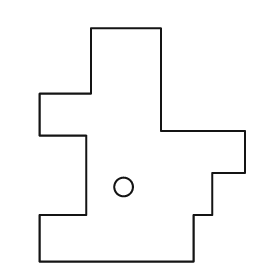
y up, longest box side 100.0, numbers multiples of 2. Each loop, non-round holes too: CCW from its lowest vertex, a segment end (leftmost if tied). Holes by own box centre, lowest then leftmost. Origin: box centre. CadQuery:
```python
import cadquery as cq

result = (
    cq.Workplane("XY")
    .moveTo(-44.0, -50.0)
    .lineTo(22.0, -50.0)
    .lineTo(22.0, -30.0)
    .lineTo(30.0, -30.0)
    .lineTo(30.0, -12.0)
    .lineTo(44.0, -12.0)
    .lineTo(44.0, 6.0)
    .lineTo(8.0, 6.0)
    .lineTo(8.0, 50.0)
    .lineTo(-22.0, 50.0)
    .lineTo(-22.0, 22.0)
    .lineTo(-44.0, 22.0)
    .lineTo(-44.0, 4.0)
    .lineTo(-24.0, 4.0)
    .lineTo(-24.0, -30.0)
    .lineTo(-44.0, -30.0)
    .close()
    .moveTo(-8.0, -18.0)
    .circle(4.0)
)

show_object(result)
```